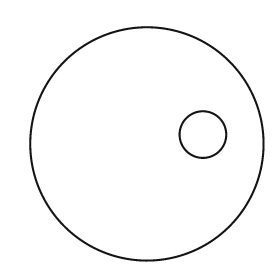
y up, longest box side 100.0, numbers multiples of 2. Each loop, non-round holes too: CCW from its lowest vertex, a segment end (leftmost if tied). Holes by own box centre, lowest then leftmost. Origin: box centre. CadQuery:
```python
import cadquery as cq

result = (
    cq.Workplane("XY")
    .moveTo(0.0, 0.0)
    .circle(50.0)
    .moveTo(24.0, 4.0)
    .circle(10.0)
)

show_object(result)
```